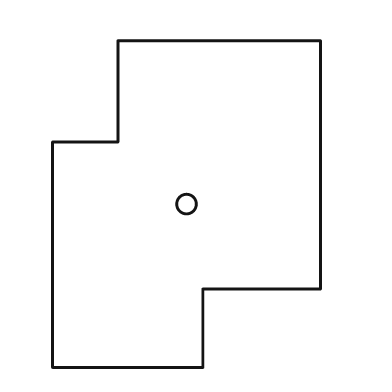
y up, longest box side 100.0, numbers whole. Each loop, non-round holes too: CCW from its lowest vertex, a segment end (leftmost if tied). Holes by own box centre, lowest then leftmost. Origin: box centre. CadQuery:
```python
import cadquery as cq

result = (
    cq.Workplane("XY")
    .moveTo(-41.0, -50.0)
    .lineTo(5.0, -50.0)
    .lineTo(5.0, -26.0)
    .lineTo(41.0, -26.0)
    .lineTo(41.0, 50.0)
    .lineTo(-21.0, 50.0)
    .lineTo(-21.0, 19.0)
    .lineTo(-41.0, 19.0)
    .close()
    .moveTo(0.0, 0.0)
    .circle(3.0)
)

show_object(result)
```